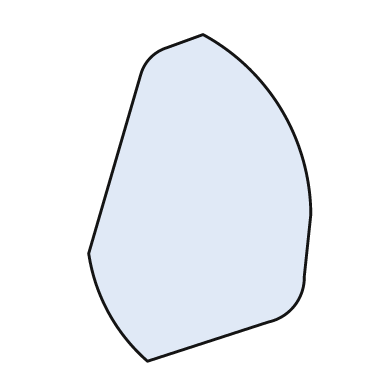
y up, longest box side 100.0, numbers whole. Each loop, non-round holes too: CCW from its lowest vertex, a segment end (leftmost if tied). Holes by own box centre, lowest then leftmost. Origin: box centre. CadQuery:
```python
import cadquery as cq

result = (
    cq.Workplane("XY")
    .moveTo(-16.0, -50.0)
    .lineTo(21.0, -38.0)
    .threePointArc((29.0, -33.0), (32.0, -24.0))
    .lineTo(34.0, -5.0)
    .threePointArc((25.0, 27.0), (1.0, 50.0))
    .lineTo(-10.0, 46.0)
    .threePointArc((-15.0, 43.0), (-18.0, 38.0))
    .lineTo(-34.0, -17.0)
    .threePointArc((-28.0, -35.0), (-16.0, -50.0))
    .close()
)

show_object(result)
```